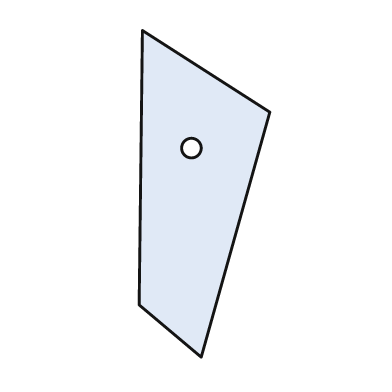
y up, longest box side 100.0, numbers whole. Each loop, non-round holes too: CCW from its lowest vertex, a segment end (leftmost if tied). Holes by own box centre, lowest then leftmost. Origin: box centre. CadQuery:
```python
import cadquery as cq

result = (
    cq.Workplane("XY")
    .moveTo(-1.0, -50.0)
    .lineTo(20.0, 25.0)
    .lineTo(-19.0, 50.0)
    .lineTo(-20.0, -34.0)
    .close()
    .moveTo(-4.0, 14.0)
    .circle(3.0)
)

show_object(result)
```